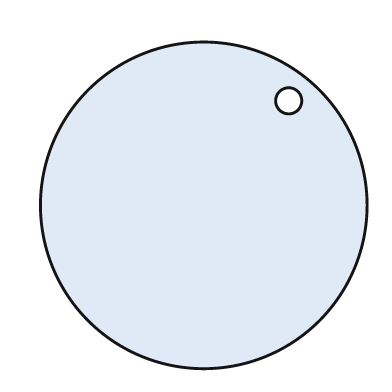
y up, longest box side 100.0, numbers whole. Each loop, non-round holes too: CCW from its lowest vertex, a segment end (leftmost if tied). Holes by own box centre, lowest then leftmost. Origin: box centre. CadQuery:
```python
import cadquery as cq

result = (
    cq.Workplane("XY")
    .moveTo(0.0, 0.0)
    .circle(50.0)
    .moveTo(26.0, 32.0)
    .circle(4.0)
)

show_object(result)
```